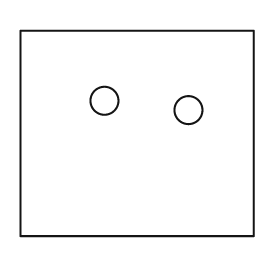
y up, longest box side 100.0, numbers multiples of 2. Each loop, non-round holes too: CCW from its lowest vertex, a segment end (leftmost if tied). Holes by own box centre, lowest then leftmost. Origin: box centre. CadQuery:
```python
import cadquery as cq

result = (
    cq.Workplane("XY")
    .moveTo(-50.0, -44.0)
    .lineTo(50.0, -44.0)
    .lineTo(50.0, 44.0)
    .lineTo(-50.0, 44.0)
    .close()
    .moveTo(22.0, 10.0)
    .circle(6.0)
    .moveTo(-14.0, 14.0)
    .circle(6.0)
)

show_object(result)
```